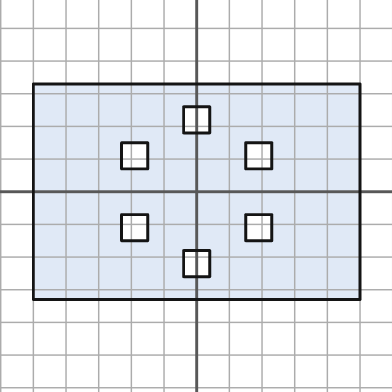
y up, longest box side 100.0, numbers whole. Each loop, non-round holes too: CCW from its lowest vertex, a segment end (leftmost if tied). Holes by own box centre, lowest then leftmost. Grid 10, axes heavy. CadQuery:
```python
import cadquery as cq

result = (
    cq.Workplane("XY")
    .moveTo(-50.0, -33.0)
    .lineTo(50.0, -33.0)
    .lineTo(50.0, 33.0)
    .lineTo(-50.0, 33.0)
    .close()
    .moveTo(-4.0, -26.0)
    .lineTo(4.0, -26.0)
    .lineTo(4.0, -18.0)
    .lineTo(-4.0, -18.0)
    .close()
    .moveTo(-23.0, -15.0)
    .lineTo(-15.0, -15.0)
    .lineTo(-15.0, -7.0)
    .lineTo(-23.0, -7.0)
    .close()
    .moveTo(15.0, -15.0)
    .lineTo(23.0, -15.0)
    .lineTo(23.0, -7.0)
    .lineTo(15.0, -7.0)
    .close()
    .moveTo(-23.0, 7.0)
    .lineTo(-15.0, 7.0)
    .lineTo(-15.0, 15.0)
    .lineTo(-23.0, 15.0)
    .close()
    .moveTo(15.0, 7.0)
    .lineTo(23.0, 7.0)
    .lineTo(23.0, 15.0)
    .lineTo(15.0, 15.0)
    .close()
    .moveTo(-4.0, 18.0)
    .lineTo(4.0, 18.0)
    .lineTo(4.0, 26.0)
    .lineTo(-4.0, 26.0)
    .close()
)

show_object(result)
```